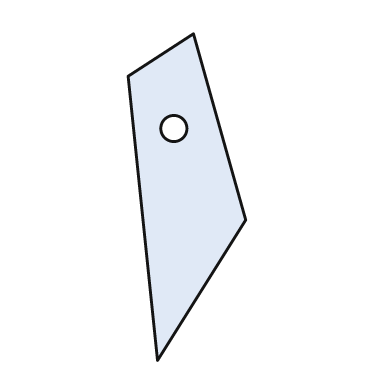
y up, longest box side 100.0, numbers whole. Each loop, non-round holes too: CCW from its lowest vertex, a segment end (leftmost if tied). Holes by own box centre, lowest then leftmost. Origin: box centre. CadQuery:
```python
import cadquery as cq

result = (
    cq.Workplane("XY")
    .moveTo(-9.0, -50.0)
    .lineTo(18.0, -7.0)
    .lineTo(2.0, 50.0)
    .lineTo(-18.0, 37.0)
    .close()
    .moveTo(-4.0, 21.0)
    .circle(4.0)
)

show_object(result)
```